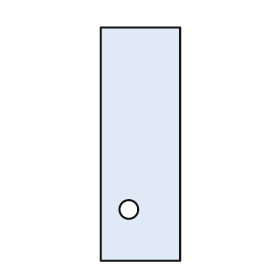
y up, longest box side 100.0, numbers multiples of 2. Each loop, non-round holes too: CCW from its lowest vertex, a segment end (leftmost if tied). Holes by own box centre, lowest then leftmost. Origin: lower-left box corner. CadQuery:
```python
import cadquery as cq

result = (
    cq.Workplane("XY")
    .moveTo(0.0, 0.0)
    .lineTo(34.0, 0.0)
    .lineTo(34.0, 100.0)
    .lineTo(0.0, 100.0)
    .close()
    .moveTo(12.0, 22.0)
    .circle(4.0)
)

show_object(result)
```